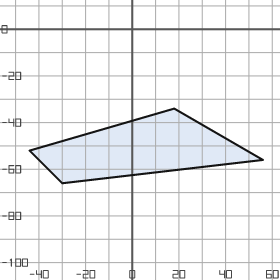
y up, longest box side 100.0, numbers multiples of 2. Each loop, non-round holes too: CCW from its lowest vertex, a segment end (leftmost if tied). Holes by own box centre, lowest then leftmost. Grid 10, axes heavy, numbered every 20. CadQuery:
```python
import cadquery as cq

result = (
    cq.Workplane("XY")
    .moveTo(-30.0, -66.0)
    .lineTo(56.0, -56.0)
    .lineTo(18.0, -34.0)
    .lineTo(-44.0, -52.0)
    .close()
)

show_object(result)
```